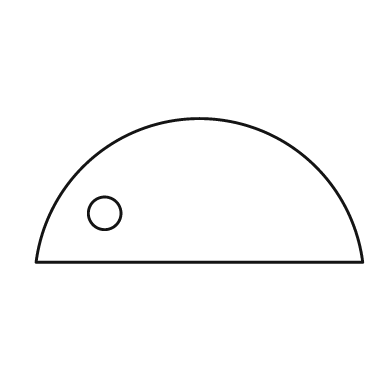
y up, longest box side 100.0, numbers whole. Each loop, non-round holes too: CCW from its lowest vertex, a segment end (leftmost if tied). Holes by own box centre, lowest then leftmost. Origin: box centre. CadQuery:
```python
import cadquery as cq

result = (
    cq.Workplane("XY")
    .moveTo(-50.0, -22.0)
    .lineTo(50.0, -22.0)
    .threePointArc((0.0, 22.0), (-50.0, -22.0))
    .close()
    .moveTo(-29.0, -7.0)
    .circle(5.0)
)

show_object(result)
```